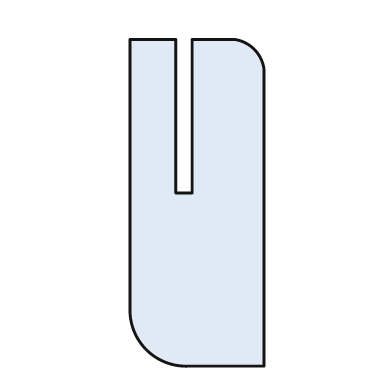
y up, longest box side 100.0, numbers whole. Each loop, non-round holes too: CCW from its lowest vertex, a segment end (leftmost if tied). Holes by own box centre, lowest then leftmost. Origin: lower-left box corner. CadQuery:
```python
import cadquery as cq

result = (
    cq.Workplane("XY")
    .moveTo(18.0, 0.0)
    .lineTo(41.0, 0.0)
    .lineTo(41.0, 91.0)
    .threePointArc((38.0, 97.0), (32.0, 100.0))
    .lineTo(19.0, 100.0)
    .lineTo(19.0, 53.0)
    .lineTo(14.0, 53.0)
    .lineTo(14.0, 100.0)
    .lineTo(0.0, 100.0)
    .lineTo(0.0, 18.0)
    .threePointArc((5.0, 5.0), (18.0, 0.0))
    .close()
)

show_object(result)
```